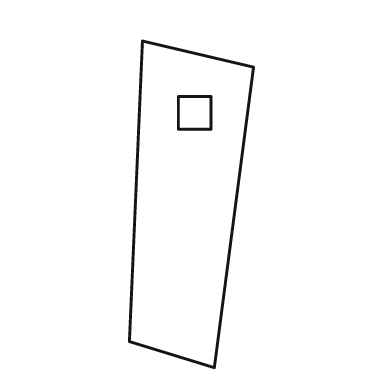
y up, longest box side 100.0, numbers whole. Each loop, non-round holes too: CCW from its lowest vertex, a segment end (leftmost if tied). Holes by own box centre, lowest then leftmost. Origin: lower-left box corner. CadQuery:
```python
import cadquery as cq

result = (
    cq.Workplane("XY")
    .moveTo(26.0, 0.0)
    .lineTo(38.0, 92.0)
    .lineTo(4.0, 100.0)
    .lineTo(0.0, 8.0)
    .close()
    .moveTo(15.0, 73.0)
    .lineTo(25.0, 73.0)
    .lineTo(25.0, 83.0)
    .lineTo(15.0, 83.0)
    .close()
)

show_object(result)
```